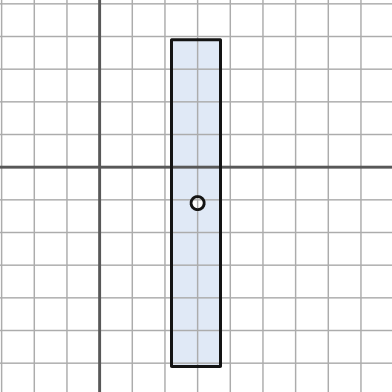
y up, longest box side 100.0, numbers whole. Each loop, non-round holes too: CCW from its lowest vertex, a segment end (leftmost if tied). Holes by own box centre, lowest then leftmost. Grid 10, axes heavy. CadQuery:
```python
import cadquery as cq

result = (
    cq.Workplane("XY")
    .moveTo(22.0, -61.0)
    .lineTo(37.0, -61.0)
    .lineTo(37.0, 39.0)
    .lineTo(22.0, 39.0)
    .close()
    .moveTo(30.0, -11.0)
    .circle(2.0)
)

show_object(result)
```